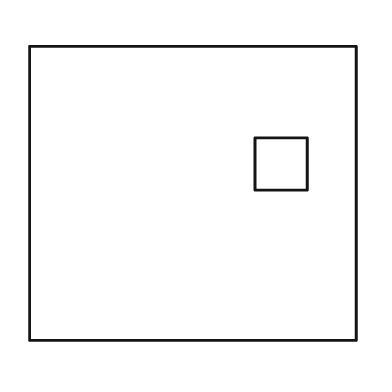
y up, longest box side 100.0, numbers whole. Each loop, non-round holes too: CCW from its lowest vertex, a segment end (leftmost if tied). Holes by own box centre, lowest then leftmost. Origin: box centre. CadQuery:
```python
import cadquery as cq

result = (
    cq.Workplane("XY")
    .moveTo(-50.0, -45.0)
    .lineTo(50.0, -45.0)
    .lineTo(50.0, 45.0)
    .lineTo(-50.0, 45.0)
    .close()
    .moveTo(19.0, 1.0)
    .lineTo(35.0, 1.0)
    .lineTo(35.0, 17.0)
    .lineTo(19.0, 17.0)
    .close()
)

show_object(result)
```